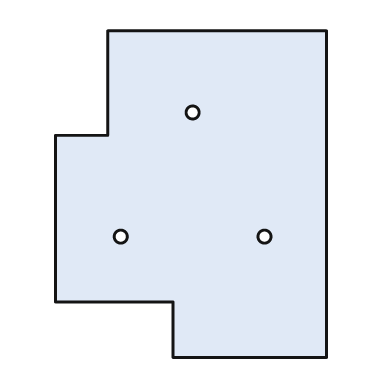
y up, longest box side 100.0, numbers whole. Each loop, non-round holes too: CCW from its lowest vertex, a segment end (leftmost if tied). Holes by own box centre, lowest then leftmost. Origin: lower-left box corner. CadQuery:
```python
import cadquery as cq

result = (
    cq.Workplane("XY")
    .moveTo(36.0, 0.0)
    .lineTo(83.0, 0.0)
    .lineTo(83.0, 100.0)
    .lineTo(16.0, 100.0)
    .lineTo(16.0, 68.0)
    .lineTo(0.0, 68.0)
    .lineTo(0.0, 17.0)
    .lineTo(36.0, 17.0)
    .close()
    .moveTo(20.0, 37.0)
    .circle(2.0)
    .moveTo(64.0, 37.0)
    .circle(2.0)
    .moveTo(42.0, 75.0)
    .circle(2.0)
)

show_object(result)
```